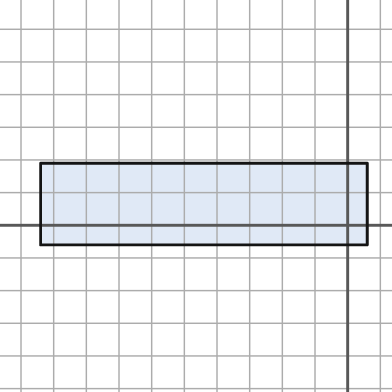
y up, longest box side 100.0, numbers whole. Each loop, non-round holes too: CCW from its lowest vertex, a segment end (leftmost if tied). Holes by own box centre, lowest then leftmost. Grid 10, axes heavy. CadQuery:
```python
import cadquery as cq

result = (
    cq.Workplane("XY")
    .moveTo(-94.0, -6.0)
    .lineTo(6.0, -6.0)
    .lineTo(6.0, 19.0)
    .lineTo(-94.0, 19.0)
    .close()
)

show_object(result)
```